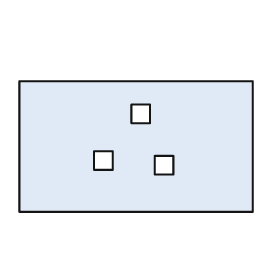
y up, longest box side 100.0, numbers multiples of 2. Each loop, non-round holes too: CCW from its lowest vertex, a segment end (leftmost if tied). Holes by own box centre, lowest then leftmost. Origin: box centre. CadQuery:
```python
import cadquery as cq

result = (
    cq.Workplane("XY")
    .moveTo(-50.0, -28.0)
    .lineTo(50.0, -28.0)
    .lineTo(50.0, 28.0)
    .lineTo(-50.0, 28.0)
    .close()
    .moveTo(8.0, -12.0)
    .lineTo(16.0, -12.0)
    .lineTo(16.0, -4.0)
    .lineTo(8.0, -4.0)
    .close()
    .moveTo(-18.0, -10.0)
    .lineTo(-10.0, -10.0)
    .lineTo(-10.0, -2.0)
    .lineTo(-18.0, -2.0)
    .close()
    .moveTo(-2.0, 10.0)
    .lineTo(6.0, 10.0)
    .lineTo(6.0, 18.0)
    .lineTo(-2.0, 18.0)
    .close()
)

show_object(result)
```